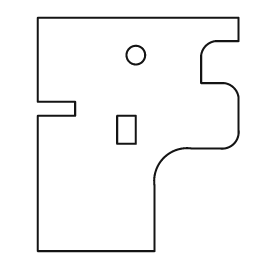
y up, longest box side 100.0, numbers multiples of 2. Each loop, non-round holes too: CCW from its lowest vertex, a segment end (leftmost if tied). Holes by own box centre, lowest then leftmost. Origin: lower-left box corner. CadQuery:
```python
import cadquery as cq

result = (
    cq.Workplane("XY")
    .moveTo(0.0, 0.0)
    .lineTo(50.0, 0.0)
    .lineTo(50.0, 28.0)
    .threePointArc((54.0, 40.0), (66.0, 44.0))
    .lineTo(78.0, 44.0)
    .threePointArc((84.0, 46.0), (86.0, 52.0))
    .lineTo(86.0, 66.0)
    .threePointArc((84.0, 70.0), (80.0, 72.0))
    .lineTo(70.0, 72.0)
    .lineTo(70.0, 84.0)
    .threePointArc((72.0, 88.0), (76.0, 90.0))
    .lineTo(86.0, 90.0)
    .lineTo(86.0, 100.0)
    .lineTo(0.0, 100.0)
    .lineTo(0.0, 64.0)
    .lineTo(16.0, 64.0)
    .lineTo(16.0, 58.0)
    .lineTo(0.0, 58.0)
    .close()
    .moveTo(34.0, 46.0)
    .lineTo(42.0, 46.0)
    .lineTo(42.0, 58.0)
    .lineTo(34.0, 58.0)
    .close()
    .moveTo(42.0, 84.0)
    .circle(4.0)
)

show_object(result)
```